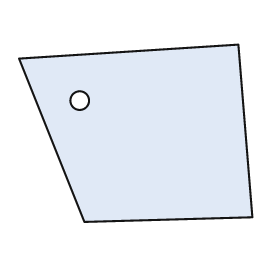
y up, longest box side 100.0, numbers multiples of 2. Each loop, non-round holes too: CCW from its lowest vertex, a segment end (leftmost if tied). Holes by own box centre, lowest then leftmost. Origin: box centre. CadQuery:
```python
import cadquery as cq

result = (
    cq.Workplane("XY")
    .moveTo(-22.0, -38.0)
    .lineTo(50.0, -36.0)
    .lineTo(44.0, 38.0)
    .lineTo(-50.0, 32.0)
    .close()
    .moveTo(-24.0, 14.0)
    .circle(4.0)
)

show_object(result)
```